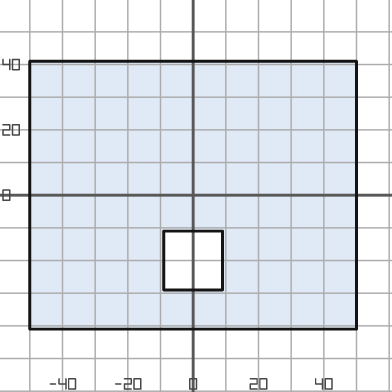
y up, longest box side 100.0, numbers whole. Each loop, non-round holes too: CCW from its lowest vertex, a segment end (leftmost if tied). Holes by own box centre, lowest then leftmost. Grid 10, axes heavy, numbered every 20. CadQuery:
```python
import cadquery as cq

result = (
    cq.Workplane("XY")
    .moveTo(-50.0, -41.0)
    .lineTo(50.0, -41.0)
    .lineTo(50.0, 41.0)
    .lineTo(-50.0, 41.0)
    .close()
    .moveTo(-9.0, -29.0)
    .lineTo(9.0, -29.0)
    .lineTo(9.0, -11.0)
    .lineTo(-9.0, -11.0)
    .close()
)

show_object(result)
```